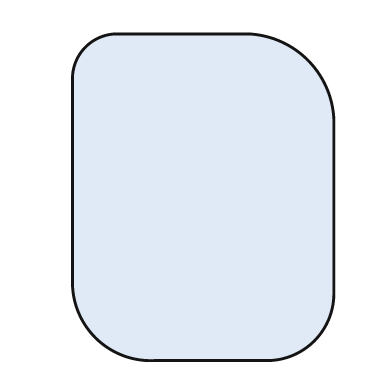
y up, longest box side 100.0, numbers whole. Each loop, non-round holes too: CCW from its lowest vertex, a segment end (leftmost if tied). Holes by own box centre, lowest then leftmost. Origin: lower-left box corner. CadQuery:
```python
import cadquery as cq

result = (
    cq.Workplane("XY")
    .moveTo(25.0, 0.0)
    .lineTo(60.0, 0.0)
    .threePointArc((74.0, 6.0), (80.0, 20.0))
    .lineTo(80.0, 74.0)
    .threePointArc((72.0, 92.0), (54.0, 100.0))
    .lineTo(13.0, 100.0)
    .threePointArc((4.0, 96.0), (0.0, 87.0))
    .lineTo(0.0, 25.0)
    .threePointArc((7.0, 7.0), (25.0, 0.0))
    .close()
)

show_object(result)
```